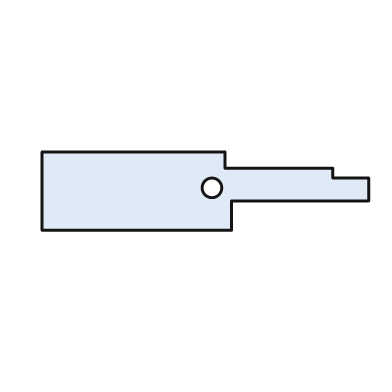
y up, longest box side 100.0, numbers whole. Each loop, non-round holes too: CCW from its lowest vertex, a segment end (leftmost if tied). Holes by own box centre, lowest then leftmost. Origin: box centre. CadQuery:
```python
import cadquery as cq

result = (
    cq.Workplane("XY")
    .moveTo(-50.0, -12.0)
    .lineTo(8.0, -12.0)
    .lineTo(8.0, -3.0)
    .lineTo(50.0, -3.0)
    .lineTo(50.0, 4.0)
    .lineTo(39.0, 4.0)
    .lineTo(39.0, 7.0)
    .lineTo(6.0, 7.0)
    .lineTo(6.0, 12.0)
    .lineTo(-50.0, 12.0)
    .close()
    .moveTo(2.0, 1.0)
    .circle(3.0)
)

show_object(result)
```